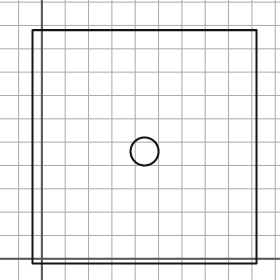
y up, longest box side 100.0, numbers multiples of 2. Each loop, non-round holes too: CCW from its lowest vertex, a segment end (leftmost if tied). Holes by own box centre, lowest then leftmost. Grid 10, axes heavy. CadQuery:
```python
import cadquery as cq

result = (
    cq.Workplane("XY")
    .moveTo(-4.0, -2.0)
    .lineTo(92.0, -2.0)
    .lineTo(92.0, 98.0)
    .lineTo(-4.0, 98.0)
    .close()
    .moveTo(44.0, 46.0)
    .circle(6.0)
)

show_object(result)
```